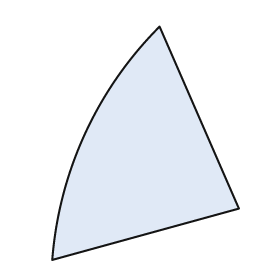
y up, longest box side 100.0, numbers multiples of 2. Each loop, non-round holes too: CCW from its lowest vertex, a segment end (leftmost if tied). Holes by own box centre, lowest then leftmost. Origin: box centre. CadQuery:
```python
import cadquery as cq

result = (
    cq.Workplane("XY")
    .moveTo(-40.0, -50.0)
    .lineTo(40.0, -28.0)
    .lineTo(6.0, 50.0)
    .threePointArc((-26.0, 4.0), (-40.0, -50.0))
    .close()
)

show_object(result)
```